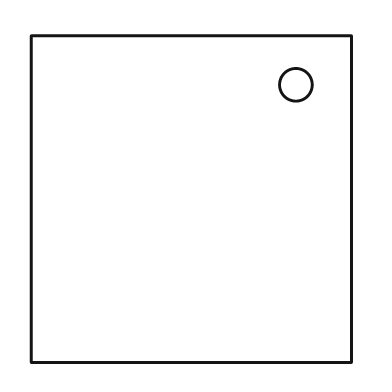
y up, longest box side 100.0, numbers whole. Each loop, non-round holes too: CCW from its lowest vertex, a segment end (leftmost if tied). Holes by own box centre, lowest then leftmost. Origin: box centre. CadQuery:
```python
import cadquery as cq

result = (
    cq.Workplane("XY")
    .moveTo(-49.0, -50.0)
    .lineTo(49.0, -50.0)
    .lineTo(49.0, 50.0)
    .lineTo(-49.0, 50.0)
    .close()
    .moveTo(32.0, 35.0)
    .circle(5.0)
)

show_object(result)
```